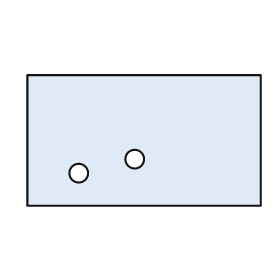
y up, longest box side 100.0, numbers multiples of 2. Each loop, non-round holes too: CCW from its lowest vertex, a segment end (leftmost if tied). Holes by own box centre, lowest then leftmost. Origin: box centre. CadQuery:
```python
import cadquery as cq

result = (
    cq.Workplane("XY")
    .moveTo(-50.0, -28.0)
    .lineTo(50.0, -28.0)
    .lineTo(50.0, 28.0)
    .lineTo(-50.0, 28.0)
    .close()
    .moveTo(-28.0, -14.0)
    .circle(4.0)
    .moveTo(-4.0, -8.0)
    .circle(4.0)
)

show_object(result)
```